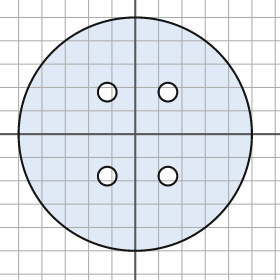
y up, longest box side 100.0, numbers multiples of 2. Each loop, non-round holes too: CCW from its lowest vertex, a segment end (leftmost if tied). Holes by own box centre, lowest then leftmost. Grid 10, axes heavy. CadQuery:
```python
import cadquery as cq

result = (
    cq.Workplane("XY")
    .moveTo(0.0, 0.0)
    .circle(50.0)
    .moveTo(-12.0, -18.0)
    .circle(4.0)
    .moveTo(14.0, -18.0)
    .circle(4.0)
    .moveTo(-12.0, 18.0)
    .circle(4.0)
    .moveTo(14.0, 18.0)
    .circle(4.0)
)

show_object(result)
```